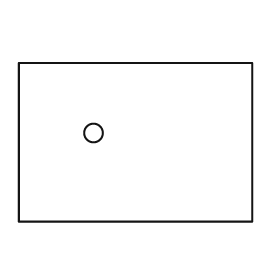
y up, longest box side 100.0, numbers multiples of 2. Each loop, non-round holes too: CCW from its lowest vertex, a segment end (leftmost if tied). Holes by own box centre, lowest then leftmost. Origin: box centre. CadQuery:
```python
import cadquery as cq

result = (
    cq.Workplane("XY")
    .moveTo(-50.0, -34.0)
    .lineTo(50.0, -34.0)
    .lineTo(50.0, 34.0)
    .lineTo(-50.0, 34.0)
    .close()
    .moveTo(-18.0, 4.0)
    .circle(4.0)
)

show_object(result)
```